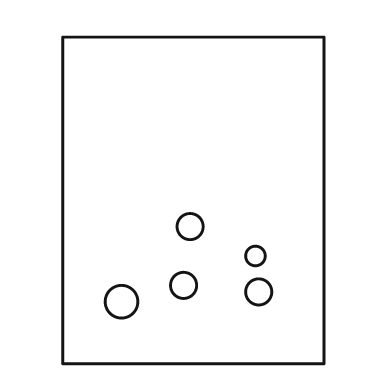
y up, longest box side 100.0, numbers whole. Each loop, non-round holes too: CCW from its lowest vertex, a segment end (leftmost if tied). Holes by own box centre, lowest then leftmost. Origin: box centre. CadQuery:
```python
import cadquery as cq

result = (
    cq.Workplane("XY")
    .moveTo(-40.0, -50.0)
    .lineTo(40.0, -50.0)
    .lineTo(40.0, 50.0)
    .lineTo(-40.0, 50.0)
    .close()
    .moveTo(-22.0, -31.0)
    .circle(5.0)
    .moveTo(20.0, -28.0)
    .circle(4.0)
    .moveTo(-3.0, -26.0)
    .circle(4.0)
    .moveTo(19.0, -17.0)
    .circle(3.0)
    .moveTo(-1.0, -8.0)
    .circle(4.0)
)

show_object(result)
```